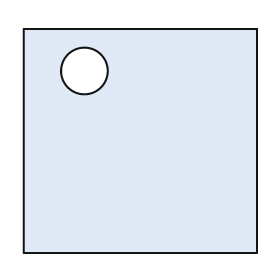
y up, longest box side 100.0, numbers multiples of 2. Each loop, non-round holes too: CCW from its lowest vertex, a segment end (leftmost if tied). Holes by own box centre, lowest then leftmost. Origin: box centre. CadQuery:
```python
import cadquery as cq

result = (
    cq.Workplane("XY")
    .moveTo(-50.0, -48.0)
    .lineTo(50.0, -48.0)
    .lineTo(50.0, 48.0)
    .lineTo(-50.0, 48.0)
    .close()
    .moveTo(-24.0, 30.0)
    .circle(10.0)
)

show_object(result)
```